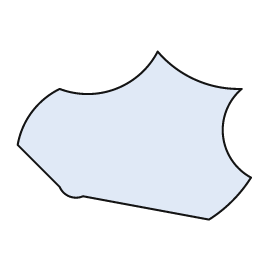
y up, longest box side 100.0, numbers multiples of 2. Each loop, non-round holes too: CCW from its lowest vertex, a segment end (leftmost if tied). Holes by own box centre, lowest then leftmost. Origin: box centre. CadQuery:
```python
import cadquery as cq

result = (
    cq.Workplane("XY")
    .moveTo(32.0, -36.0)
    .threePointArc((42.0, -28.0), (50.0, -18.0))
    .threePointArc((38.0, 0.0), (46.0, 20.0))
    .threePointArc((26.0, 24.0), (10.0, 36.0))
    .threePointArc((-8.0, 20.0), (-32.0, 20.0))
    .threePointArc((-44.0, 10.0), (-50.0, -4.0))
    .lineTo(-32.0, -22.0)
    .threePointArc((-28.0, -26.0), (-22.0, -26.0))
    .close()
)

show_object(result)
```